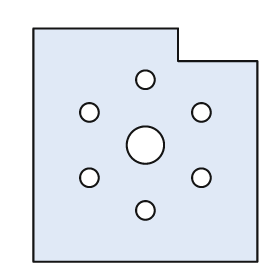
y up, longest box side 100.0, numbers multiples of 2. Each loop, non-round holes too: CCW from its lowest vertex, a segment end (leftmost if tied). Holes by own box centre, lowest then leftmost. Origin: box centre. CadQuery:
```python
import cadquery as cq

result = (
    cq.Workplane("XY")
    .moveTo(-48.0, -50.0)
    .lineTo(48.0, -50.0)
    .lineTo(48.0, 36.0)
    .lineTo(14.0, 36.0)
    .lineTo(14.0, 50.0)
    .lineTo(-48.0, 50.0)
    .close()
    .moveTo(0.0, -28.0)
    .circle(4.0)
    .moveTo(-24.0, -14.0)
    .circle(4.0)
    .moveTo(24.0, -14.0)
    .circle(4.0)
    .moveTo(0.0, 0.0)
    .circle(8.0)
    .moveTo(-24.0, 14.0)
    .circle(4.0)
    .moveTo(24.0, 14.0)
    .circle(4.0)
    .moveTo(0.0, 28.0)
    .circle(4.0)
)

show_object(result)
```